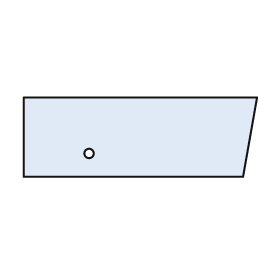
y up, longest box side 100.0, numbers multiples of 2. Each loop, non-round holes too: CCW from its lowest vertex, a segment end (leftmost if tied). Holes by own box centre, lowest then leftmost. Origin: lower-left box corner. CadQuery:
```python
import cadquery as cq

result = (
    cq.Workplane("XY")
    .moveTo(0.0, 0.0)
    .lineTo(94.0, 0.0)
    .lineTo(100.0, 34.0)
    .lineTo(0.0, 34.0)
    .close()
    .moveTo(28.0, 10.0)
    .circle(2.0)
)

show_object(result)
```